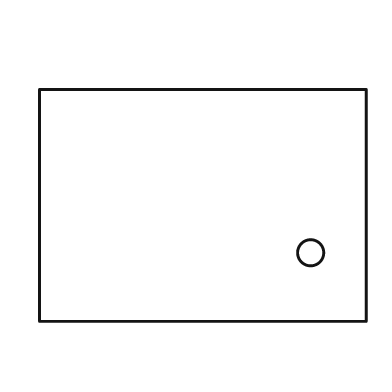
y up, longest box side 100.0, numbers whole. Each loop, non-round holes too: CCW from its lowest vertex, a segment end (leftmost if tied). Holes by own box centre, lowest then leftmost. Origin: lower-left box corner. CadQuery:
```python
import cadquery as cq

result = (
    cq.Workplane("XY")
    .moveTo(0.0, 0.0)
    .lineTo(100.0, 0.0)
    .lineTo(100.0, 71.0)
    .lineTo(0.0, 71.0)
    .close()
    .moveTo(83.0, 21.0)
    .circle(4.0)
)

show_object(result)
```